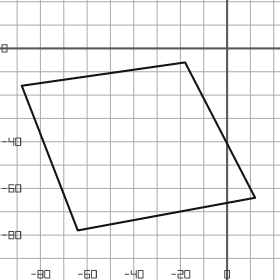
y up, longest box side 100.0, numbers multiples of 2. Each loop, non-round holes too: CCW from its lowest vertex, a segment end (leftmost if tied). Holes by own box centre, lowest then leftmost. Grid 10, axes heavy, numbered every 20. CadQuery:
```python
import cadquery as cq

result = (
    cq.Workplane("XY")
    .moveTo(-64.0, -78.0)
    .lineTo(12.0, -64.0)
    .lineTo(-18.0, -6.0)
    .lineTo(-88.0, -16.0)
    .close()
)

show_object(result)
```